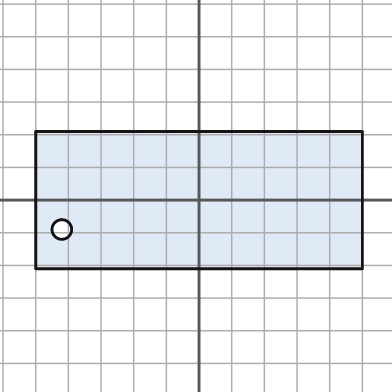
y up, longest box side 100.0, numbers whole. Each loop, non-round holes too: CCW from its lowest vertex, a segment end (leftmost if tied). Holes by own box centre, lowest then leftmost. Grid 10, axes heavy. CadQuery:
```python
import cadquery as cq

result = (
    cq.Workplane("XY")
    .moveTo(-50.0, -21.0)
    .lineTo(50.0, -21.0)
    .lineTo(50.0, 21.0)
    .lineTo(-50.0, 21.0)
    .close()
    .moveTo(-42.0, -9.0)
    .circle(3.0)
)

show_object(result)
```